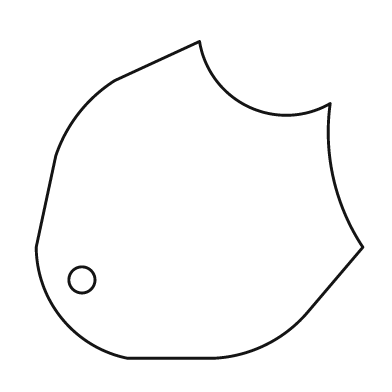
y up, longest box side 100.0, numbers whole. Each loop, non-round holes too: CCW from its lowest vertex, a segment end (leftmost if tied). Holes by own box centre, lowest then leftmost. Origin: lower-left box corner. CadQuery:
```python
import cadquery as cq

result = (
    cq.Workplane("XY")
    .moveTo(28.0, 0.0)
    .lineTo(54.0, 0.0)
    .threePointArc((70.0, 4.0), (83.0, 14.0))
    .lineTo(100.0, 34.0)
    .threePointArc((91.0, 55.0), (90.0, 78.0))
    .threePointArc((65.0, 77.0), (50.0, 97.0))
    .lineTo(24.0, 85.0)
    .threePointArc((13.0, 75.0), (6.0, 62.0))
    .lineTo(0.0, 34.0)
    .threePointArc((8.0, 12.0), (28.0, 0.0))
    .close()
    .moveTo(14.0, 24.0)
    .circle(4.0)
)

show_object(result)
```